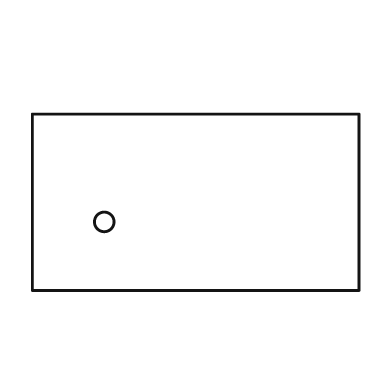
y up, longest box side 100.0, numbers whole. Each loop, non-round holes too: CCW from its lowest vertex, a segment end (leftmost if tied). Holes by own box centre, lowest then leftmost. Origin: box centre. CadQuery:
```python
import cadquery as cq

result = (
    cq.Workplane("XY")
    .moveTo(-50.0, -27.0)
    .lineTo(50.0, -27.0)
    .lineTo(50.0, 27.0)
    .lineTo(-50.0, 27.0)
    .close()
    .moveTo(-28.0, -6.0)
    .circle(3.0)
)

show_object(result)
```